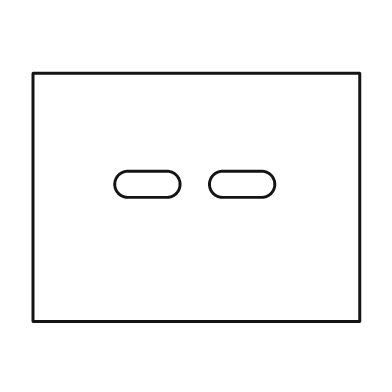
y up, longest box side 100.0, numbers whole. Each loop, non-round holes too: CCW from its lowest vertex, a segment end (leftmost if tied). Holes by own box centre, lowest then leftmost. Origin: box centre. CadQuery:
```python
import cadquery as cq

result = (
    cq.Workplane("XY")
    .moveTo(-50.0, -38.0)
    .lineTo(50.0, -38.0)
    .lineTo(50.0, 38.0)
    .lineTo(-50.0, 38.0)
    .close()
    .moveTo(-21.0, 0.0)
    .lineTo(-9.0, 0.0)
    .threePointArc((-5.0, 4.0), (-9.0, 8.0))
    .lineTo(-21.0, 8.0)
    .threePointArc((-25.0, 4.0), (-21.0, 0.0))
    .close()
    .moveTo(8.0, 0.0)
    .lineTo(20.0, 0.0)
    .threePointArc((24.0, 4.0), (20.0, 8.0))
    .lineTo(8.0, 8.0)
    .threePointArc((4.0, 4.0), (8.0, 0.0))
    .close()
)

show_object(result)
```